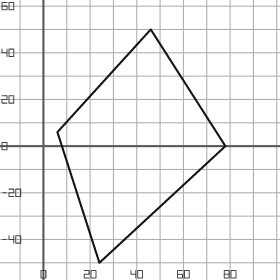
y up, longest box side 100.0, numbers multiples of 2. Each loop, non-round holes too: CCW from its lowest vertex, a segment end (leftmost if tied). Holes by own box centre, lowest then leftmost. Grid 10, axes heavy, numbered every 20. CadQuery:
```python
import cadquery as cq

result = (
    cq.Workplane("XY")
    .moveTo(24.0, -50.0)
    .lineTo(78.0, 0.0)
    .lineTo(46.0, 50.0)
    .lineTo(6.0, 6.0)
    .close()
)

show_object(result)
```